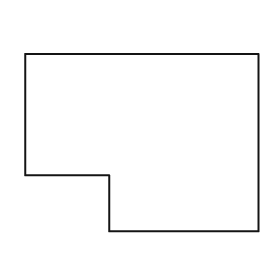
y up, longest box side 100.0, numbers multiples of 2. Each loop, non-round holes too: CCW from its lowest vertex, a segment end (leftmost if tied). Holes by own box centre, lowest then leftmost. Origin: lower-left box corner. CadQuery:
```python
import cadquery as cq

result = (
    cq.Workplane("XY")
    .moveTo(36.0, 0.0)
    .lineTo(100.0, 0.0)
    .lineTo(100.0, 76.0)
    .lineTo(0.0, 76.0)
    .lineTo(0.0, 24.0)
    .lineTo(36.0, 24.0)
    .close()
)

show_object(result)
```